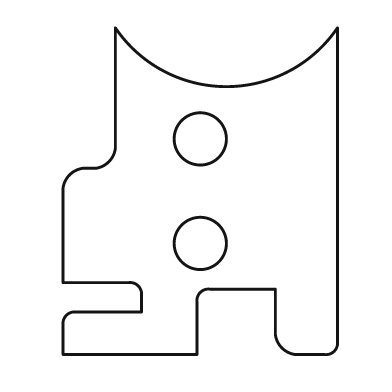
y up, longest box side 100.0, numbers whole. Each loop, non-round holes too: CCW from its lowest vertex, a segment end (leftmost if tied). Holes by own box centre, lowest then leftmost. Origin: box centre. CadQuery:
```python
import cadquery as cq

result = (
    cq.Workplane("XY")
    .moveTo(-42.0, -50.0)
    .lineTo(-1.0, -50.0)
    .lineTo(-1.0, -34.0)
    .threePointArc((0.0, -31.0), (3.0, -30.0))
    .lineTo(23.0, -30.0)
    .lineTo(23.0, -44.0)
    .threePointArc((25.0, -48.0), (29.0, -50.0))
    .lineTo(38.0, -50.0)
    .threePointArc((41.0, -49.0), (42.0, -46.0))
    .lineTo(42.0, 50.0)
    .threePointArc((8.0, 32.0), (-26.0, 50.0))
    .lineTo(-26.0, 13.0)
    .threePointArc((-28.0, 9.0), (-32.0, 7.0))
    .lineTo(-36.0, 7.0)
    .threePointArc((-40.0, 5.0), (-42.0, 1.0))
    .lineTo(-42.0, -28.0)
    .lineTo(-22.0, -28.0)
    .threePointArc((-19.0, -29.0), (-18.0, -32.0))
    .lineTo(-18.0, -37.0)
    .lineTo(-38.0, -37.0)
    .threePointArc((-41.0, -38.0), (-42.0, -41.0))
    .close()
    .moveTo(0.0, -16.0)
    .circle(8.0)
    .moveTo(0.0, 16.0)
    .circle(8.0)
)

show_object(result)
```